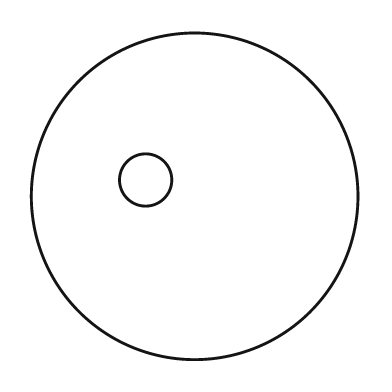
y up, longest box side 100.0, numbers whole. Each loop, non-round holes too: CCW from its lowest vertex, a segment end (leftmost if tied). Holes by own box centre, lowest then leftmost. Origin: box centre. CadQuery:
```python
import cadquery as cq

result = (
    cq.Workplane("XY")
    .moveTo(0.0, 0.0)
    .circle(50.0)
    .moveTo(-15.0, 5.0)
    .circle(8.0)
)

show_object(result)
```